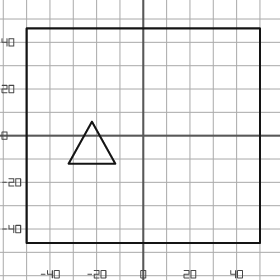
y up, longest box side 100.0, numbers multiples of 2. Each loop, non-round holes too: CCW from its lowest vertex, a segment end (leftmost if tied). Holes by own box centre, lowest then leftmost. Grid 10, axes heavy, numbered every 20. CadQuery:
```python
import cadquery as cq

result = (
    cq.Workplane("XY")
    .moveTo(-50.0, -46.0)
    .lineTo(50.0, -46.0)
    .lineTo(50.0, 46.0)
    .lineTo(-50.0, 46.0)
    .close()
    .moveTo(-32.0, -12.0)
    .lineTo(-12.0, -12.0)
    .lineTo(-22.0, 6.0)
    .close()
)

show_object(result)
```